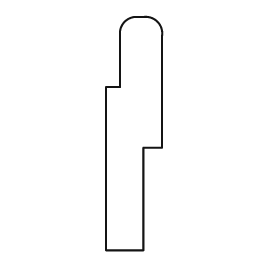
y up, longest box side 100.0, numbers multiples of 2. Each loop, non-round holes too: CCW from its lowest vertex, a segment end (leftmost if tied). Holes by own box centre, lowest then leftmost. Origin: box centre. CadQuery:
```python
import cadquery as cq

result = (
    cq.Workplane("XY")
    .moveTo(-12.0, -50.0)
    .lineTo(4.0, -50.0)
    .lineTo(4.0, -6.0)
    .lineTo(12.0, -6.0)
    .lineTo(12.0, 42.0)
    .threePointArc((10.0, 48.0), (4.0, 50.0))
    .lineTo(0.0, 50.0)
    .threePointArc((-4.0, 48.0), (-6.0, 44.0))
    .lineTo(-6.0, 20.0)
    .lineTo(-12.0, 20.0)
    .close()
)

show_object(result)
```